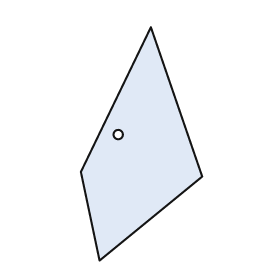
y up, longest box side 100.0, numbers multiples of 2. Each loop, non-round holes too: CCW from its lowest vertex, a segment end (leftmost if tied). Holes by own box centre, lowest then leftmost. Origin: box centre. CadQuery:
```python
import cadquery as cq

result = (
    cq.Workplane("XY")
    .moveTo(-18.0, -50.0)
    .lineTo(26.0, -14.0)
    .lineTo(4.0, 50.0)
    .lineTo(-26.0, -12.0)
    .close()
    .moveTo(-10.0, 4.0)
    .circle(2.0)
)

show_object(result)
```